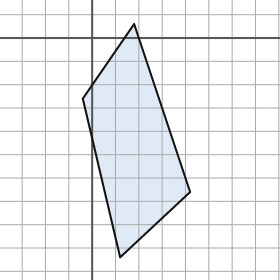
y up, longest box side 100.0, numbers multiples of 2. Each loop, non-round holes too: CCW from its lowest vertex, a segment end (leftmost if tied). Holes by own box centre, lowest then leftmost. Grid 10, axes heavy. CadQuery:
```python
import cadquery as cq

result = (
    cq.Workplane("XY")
    .moveTo(12.0, -94.0)
    .lineTo(42.0, -66.0)
    .lineTo(18.0, 6.0)
    .lineTo(-4.0, -26.0)
    .close()
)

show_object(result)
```